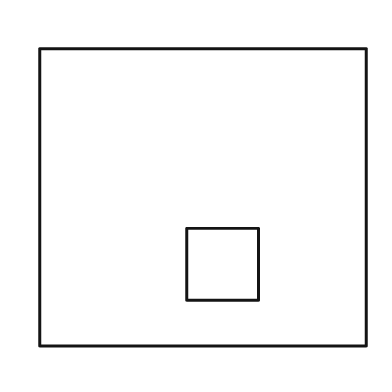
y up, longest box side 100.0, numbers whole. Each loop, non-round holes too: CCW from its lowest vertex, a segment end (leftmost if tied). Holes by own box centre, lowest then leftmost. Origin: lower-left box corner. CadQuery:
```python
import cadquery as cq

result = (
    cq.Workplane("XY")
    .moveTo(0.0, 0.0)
    .lineTo(100.0, 0.0)
    .lineTo(100.0, 91.0)
    .lineTo(0.0, 91.0)
    .close()
    .moveTo(45.0, 14.0)
    .lineTo(67.0, 14.0)
    .lineTo(67.0, 36.0)
    .lineTo(45.0, 36.0)
    .close()
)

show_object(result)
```